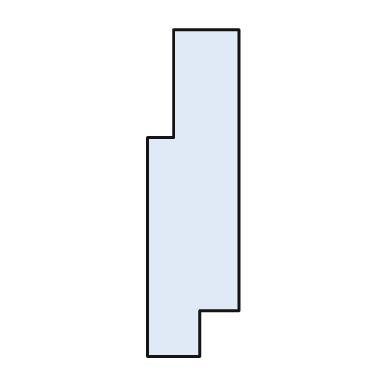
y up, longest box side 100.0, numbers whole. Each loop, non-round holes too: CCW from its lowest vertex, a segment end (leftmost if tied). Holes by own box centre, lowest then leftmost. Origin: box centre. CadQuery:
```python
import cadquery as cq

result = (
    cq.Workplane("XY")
    .moveTo(-14.0, -50.0)
    .lineTo(2.0, -50.0)
    .lineTo(2.0, -36.0)
    .lineTo(14.0, -36.0)
    .lineTo(14.0, 50.0)
    .lineTo(-6.0, 50.0)
    .lineTo(-6.0, 17.0)
    .lineTo(-14.0, 17.0)
    .close()
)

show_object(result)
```